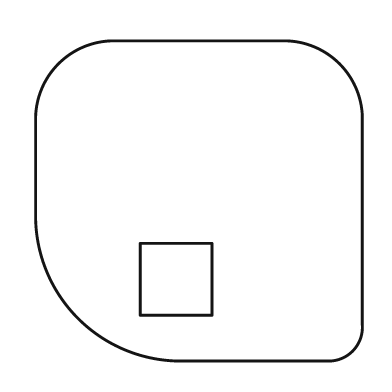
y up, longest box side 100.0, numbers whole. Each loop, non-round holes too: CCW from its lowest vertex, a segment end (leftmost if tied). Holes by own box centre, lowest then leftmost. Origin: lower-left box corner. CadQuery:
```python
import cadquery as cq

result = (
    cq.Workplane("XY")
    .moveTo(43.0, 0.0)
    .lineTo(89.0, 0.0)
    .threePointArc((97.0, 3.0), (100.0, 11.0))
    .lineTo(100.0, 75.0)
    .threePointArc((93.0, 91.0), (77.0, 98.0))
    .lineTo(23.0, 98.0)
    .threePointArc((7.0, 91.0), (0.0, 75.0))
    .lineTo(0.0, 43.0)
    .threePointArc((13.0, 13.0), (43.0, 0.0))
    .close()
    .moveTo(32.0, 14.0)
    .lineTo(54.0, 14.0)
    .lineTo(54.0, 36.0)
    .lineTo(32.0, 36.0)
    .close()
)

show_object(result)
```